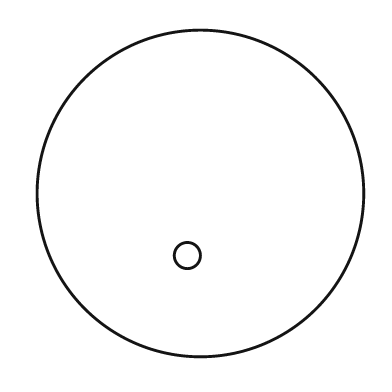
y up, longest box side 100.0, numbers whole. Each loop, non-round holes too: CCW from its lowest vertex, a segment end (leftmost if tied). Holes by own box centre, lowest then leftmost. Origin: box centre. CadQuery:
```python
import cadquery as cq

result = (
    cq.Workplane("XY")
    .moveTo(0.0, 0.0)
    .circle(50.0)
    .moveTo(-4.0, -19.0)
    .circle(4.0)
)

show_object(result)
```